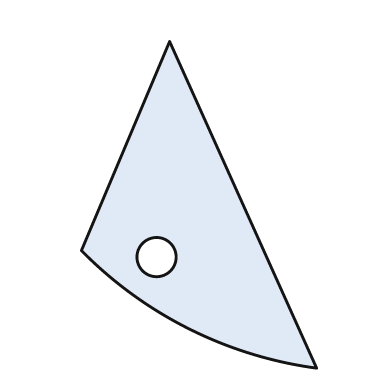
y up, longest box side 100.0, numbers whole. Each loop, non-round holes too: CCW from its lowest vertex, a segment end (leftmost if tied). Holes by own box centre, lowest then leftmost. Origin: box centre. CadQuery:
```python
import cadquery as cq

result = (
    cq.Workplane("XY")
    .moveTo(36.0, -50.0)
    .lineTo(-9.0, 50.0)
    .lineTo(-36.0, -14.0)
    .threePointArc((-3.0, -38.0), (36.0, -50.0))
    .close()
    .moveTo(-13.0, -16.0)
    .circle(6.0)
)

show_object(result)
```